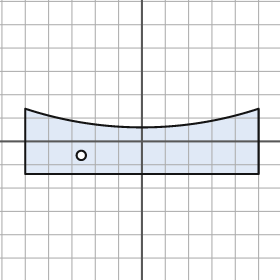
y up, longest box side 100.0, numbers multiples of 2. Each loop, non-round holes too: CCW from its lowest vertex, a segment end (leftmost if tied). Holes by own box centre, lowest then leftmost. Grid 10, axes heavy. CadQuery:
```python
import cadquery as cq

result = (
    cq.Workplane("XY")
    .moveTo(-50.0, -14.0)
    .lineTo(50.0, -14.0)
    .lineTo(50.0, 14.0)
    .threePointArc((0.0, 6.0), (-50.0, 14.0))
    .close()
    .moveTo(-26.0, -6.0)
    .circle(2.0)
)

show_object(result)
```